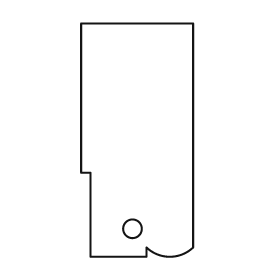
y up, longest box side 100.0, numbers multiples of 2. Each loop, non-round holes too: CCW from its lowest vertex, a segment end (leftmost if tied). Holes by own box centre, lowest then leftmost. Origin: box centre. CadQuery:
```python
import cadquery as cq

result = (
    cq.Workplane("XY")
    .moveTo(-20.0, -50.0)
    .lineTo(4.0, -50.0)
    .lineTo(4.0, -46.0)
    .threePointArc((14.0, -50.0), (24.0, -46.0))
    .lineTo(24.0, 50.0)
    .lineTo(-24.0, 50.0)
    .lineTo(-24.0, -14.0)
    .lineTo(-20.0, -14.0)
    .close()
    .moveTo(-2.0, -38.0)
    .circle(4.0)
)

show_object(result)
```